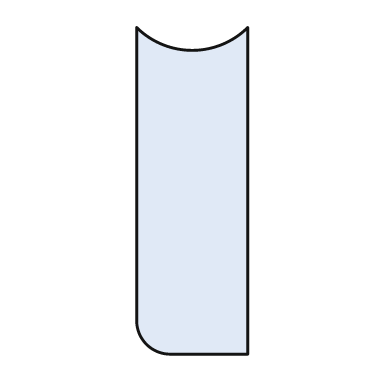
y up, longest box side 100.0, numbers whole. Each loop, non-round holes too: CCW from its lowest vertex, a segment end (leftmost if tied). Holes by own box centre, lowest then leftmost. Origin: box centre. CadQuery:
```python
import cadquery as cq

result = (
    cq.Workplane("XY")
    .moveTo(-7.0, -50.0)
    .lineTo(17.0, -50.0)
    .lineTo(17.0, 50.0)
    .threePointArc((0.0, 43.0), (-17.0, 50.0))
    .lineTo(-17.0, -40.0)
    .threePointArc((-14.0, -47.0), (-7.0, -50.0))
    .close()
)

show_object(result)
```